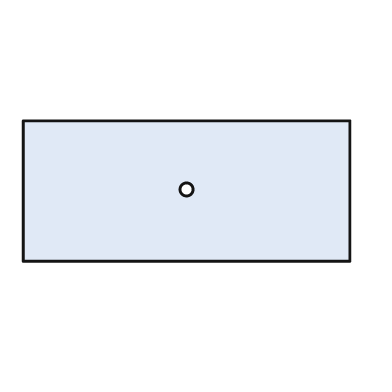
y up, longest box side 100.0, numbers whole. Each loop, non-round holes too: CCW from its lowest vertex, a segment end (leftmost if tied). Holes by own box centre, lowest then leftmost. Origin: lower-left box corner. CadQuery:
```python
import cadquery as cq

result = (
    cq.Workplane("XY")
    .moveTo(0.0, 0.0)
    .lineTo(100.0, 0.0)
    .lineTo(100.0, 43.0)
    .lineTo(0.0, 43.0)
    .close()
    .moveTo(50.0, 22.0)
    .circle(2.0)
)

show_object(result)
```